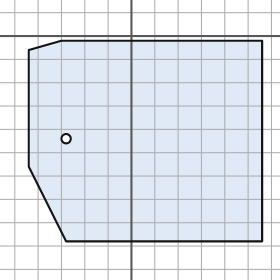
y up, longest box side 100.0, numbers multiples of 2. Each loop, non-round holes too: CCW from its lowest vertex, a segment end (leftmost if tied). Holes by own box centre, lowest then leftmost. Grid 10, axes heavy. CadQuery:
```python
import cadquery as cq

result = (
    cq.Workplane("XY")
    .moveTo(-28.0, -88.0)
    .lineTo(56.0, -88.0)
    .lineTo(56.0, -2.0)
    .lineTo(-30.0, -2.0)
    .lineTo(-44.0, -6.0)
    .lineTo(-44.0, -56.0)
    .close()
    .moveTo(-28.0, -44.0)
    .circle(2.0)
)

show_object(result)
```